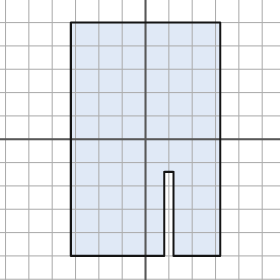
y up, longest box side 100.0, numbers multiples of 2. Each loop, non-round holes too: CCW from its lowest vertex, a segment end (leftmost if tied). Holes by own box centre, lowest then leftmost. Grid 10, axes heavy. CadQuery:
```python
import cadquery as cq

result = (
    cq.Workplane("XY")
    .moveTo(-32.0, -50.0)
    .lineTo(8.0, -50.0)
    .lineTo(8.0, -14.0)
    .lineTo(12.0, -14.0)
    .lineTo(12.0, -50.0)
    .lineTo(32.0, -50.0)
    .lineTo(32.0, 50.0)
    .lineTo(-32.0, 50.0)
    .close()
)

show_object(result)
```